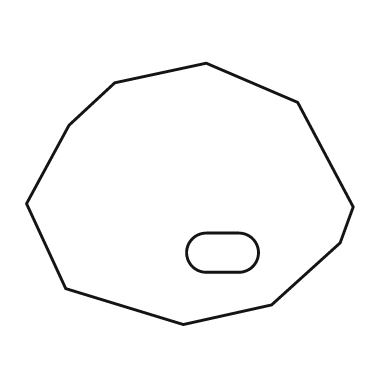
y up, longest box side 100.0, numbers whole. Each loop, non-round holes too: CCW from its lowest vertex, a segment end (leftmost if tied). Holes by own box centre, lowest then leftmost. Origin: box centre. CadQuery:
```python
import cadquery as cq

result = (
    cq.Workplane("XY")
    .moveTo(-2.0, -40.0)
    .lineTo(25.0, -34.0)
    .lineTo(46.0, -15.0)
    .lineTo(50.0, -4.0)
    .lineTo(33.0, 28.0)
    .lineTo(5.0, 40.0)
    .lineTo(-23.0, 34.0)
    .lineTo(-37.0, 21.0)
    .lineTo(-50.0, -3.0)
    .lineTo(-38.0, -29.0)
    .close()
    .moveTo(5.0, -24.0)
    .lineTo(15.0, -24.0)
    .threePointArc((21.0, -18.0), (15.0, -12.0))
    .lineTo(5.0, -12.0)
    .threePointArc((-1.0, -18.0), (5.0, -24.0))
    .close()
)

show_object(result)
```